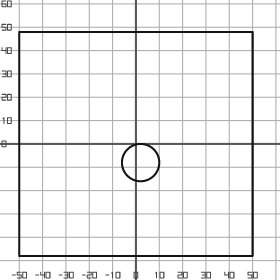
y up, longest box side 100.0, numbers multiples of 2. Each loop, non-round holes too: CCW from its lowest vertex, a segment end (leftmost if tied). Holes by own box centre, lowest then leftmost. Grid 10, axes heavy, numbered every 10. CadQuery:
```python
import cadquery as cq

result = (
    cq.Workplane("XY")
    .moveTo(-50.0, -48.0)
    .lineTo(50.0, -48.0)
    .lineTo(50.0, 48.0)
    .lineTo(-50.0, 48.0)
    .close()
    .moveTo(2.0, -8.0)
    .circle(8.0)
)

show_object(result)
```